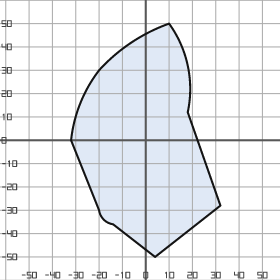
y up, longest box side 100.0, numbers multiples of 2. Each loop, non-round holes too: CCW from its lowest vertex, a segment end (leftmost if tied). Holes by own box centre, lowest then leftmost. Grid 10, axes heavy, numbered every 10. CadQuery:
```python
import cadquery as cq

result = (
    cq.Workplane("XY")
    .moveTo(4.0, -50.0)
    .lineTo(32.0, -28.0)
    .lineTo(18.0, 12.0)
    .threePointArc((18.0, 32.0), (10.0, 50.0))
    .threePointArc((-6.0, 42.0), (-20.0, 30.0))
    .threePointArc((-28.0, 16.0), (-32.0, 0.0))
    .lineTo(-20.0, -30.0)
    .threePointArc((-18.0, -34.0), (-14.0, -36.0))
    .close()
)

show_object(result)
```